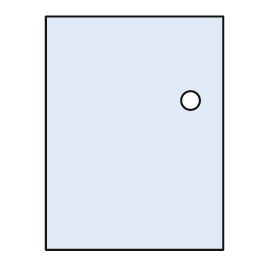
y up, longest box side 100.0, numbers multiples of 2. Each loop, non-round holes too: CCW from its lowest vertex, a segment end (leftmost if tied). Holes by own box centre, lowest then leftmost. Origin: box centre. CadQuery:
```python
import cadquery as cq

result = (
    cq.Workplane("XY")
    .moveTo(-38.0, -50.0)
    .lineTo(38.0, -50.0)
    .lineTo(38.0, 50.0)
    .lineTo(-38.0, 50.0)
    .close()
    .moveTo(24.0, 14.0)
    .circle(4.0)
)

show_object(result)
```